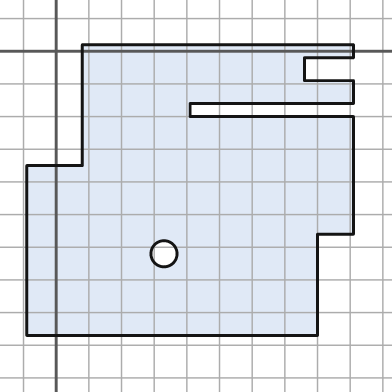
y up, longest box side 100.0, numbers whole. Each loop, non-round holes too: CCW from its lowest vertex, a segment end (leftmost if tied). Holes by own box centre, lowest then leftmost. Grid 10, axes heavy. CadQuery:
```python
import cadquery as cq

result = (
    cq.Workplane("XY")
    .moveTo(-9.0, -87.0)
    .lineTo(80.0, -87.0)
    .lineTo(80.0, -56.0)
    .lineTo(91.0, -56.0)
    .lineTo(91.0, -20.0)
    .lineTo(41.0, -20.0)
    .lineTo(41.0, -16.0)
    .lineTo(91.0, -16.0)
    .lineTo(91.0, -9.0)
    .lineTo(76.0, -9.0)
    .lineTo(76.0, -2.0)
    .lineTo(91.0, -2.0)
    .lineTo(91.0, 2.0)
    .lineTo(8.0, 2.0)
    .lineTo(8.0, -35.0)
    .lineTo(-9.0, -35.0)
    .close()
    .moveTo(33.0, -62.0)
    .circle(4.0)
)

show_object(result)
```